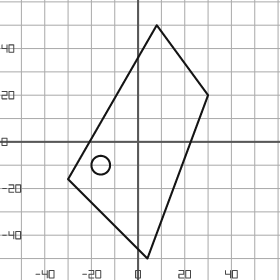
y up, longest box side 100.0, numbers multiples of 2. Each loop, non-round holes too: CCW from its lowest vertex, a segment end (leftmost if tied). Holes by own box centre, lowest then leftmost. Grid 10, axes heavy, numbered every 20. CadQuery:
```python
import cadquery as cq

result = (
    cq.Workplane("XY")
    .moveTo(4.0, -50.0)
    .lineTo(30.0, 20.0)
    .lineTo(8.0, 50.0)
    .lineTo(-30.0, -16.0)
    .close()
    .moveTo(-16.0, -10.0)
    .circle(4.0)
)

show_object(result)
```